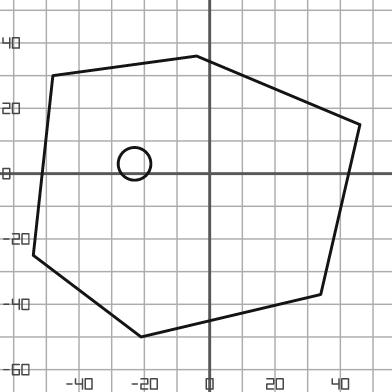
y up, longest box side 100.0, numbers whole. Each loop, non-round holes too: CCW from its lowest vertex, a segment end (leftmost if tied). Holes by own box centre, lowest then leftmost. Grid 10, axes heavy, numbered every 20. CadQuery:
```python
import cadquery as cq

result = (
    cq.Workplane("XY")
    .moveTo(-21.0, -50.0)
    .lineTo(34.0, -37.0)
    .lineTo(46.0, 15.0)
    .lineTo(-4.0, 36.0)
    .lineTo(-48.0, 30.0)
    .lineTo(-54.0, -25.0)
    .close()
    .moveTo(-23.0, 3.0)
    .circle(5.0)
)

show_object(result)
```